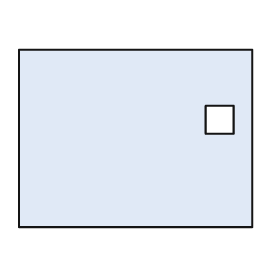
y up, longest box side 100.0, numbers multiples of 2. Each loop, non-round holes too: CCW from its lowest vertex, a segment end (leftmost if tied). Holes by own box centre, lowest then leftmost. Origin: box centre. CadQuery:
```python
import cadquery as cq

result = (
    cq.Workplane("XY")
    .moveTo(-50.0, -38.0)
    .lineTo(50.0, -38.0)
    .lineTo(50.0, 38.0)
    .lineTo(-50.0, 38.0)
    .close()
    .moveTo(30.0, 2.0)
    .lineTo(42.0, 2.0)
    .lineTo(42.0, 14.0)
    .lineTo(30.0, 14.0)
    .close()
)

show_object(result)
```